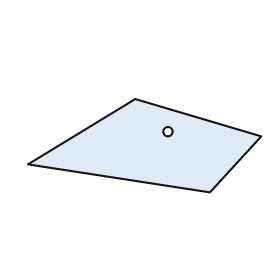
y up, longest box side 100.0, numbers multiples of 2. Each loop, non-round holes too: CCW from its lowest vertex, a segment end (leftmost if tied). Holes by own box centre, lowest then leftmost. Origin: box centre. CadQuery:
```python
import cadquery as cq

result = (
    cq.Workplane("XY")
    .moveTo(28.0, -20.0)
    .lineTo(50.0, 4.0)
    .lineTo(-4.0, 20.0)
    .lineTo(-50.0, -8.0)
    .close()
    .moveTo(10.0, 6.0)
    .circle(2.0)
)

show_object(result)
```